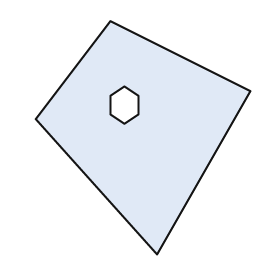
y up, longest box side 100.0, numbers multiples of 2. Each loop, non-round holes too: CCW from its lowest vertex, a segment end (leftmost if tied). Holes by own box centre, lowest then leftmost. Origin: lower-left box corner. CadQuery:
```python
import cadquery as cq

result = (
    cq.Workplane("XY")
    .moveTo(52.0, 0.0)
    .lineTo(92.0, 70.0)
    .lineTo(32.0, 100.0)
    .lineTo(0.0, 58.0)
    .close()
    .moveTo(38.0, 56.0)
    .lineTo(44.0, 60.0)
    .lineTo(44.0, 68.0)
    .lineTo(38.0, 72.0)
    .lineTo(32.0, 68.0)
    .lineTo(32.0, 60.0)
    .close()
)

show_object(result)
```